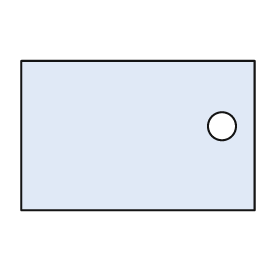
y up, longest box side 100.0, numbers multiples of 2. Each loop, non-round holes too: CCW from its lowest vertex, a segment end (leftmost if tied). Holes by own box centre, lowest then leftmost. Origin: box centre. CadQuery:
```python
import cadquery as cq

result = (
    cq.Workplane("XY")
    .moveTo(-50.0, -32.0)
    .lineTo(50.0, -32.0)
    .lineTo(50.0, 32.0)
    .lineTo(-50.0, 32.0)
    .close()
    .moveTo(36.0, 4.0)
    .circle(6.0)
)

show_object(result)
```